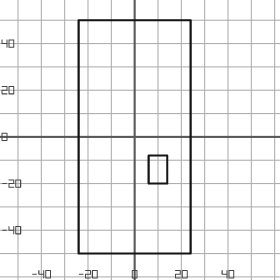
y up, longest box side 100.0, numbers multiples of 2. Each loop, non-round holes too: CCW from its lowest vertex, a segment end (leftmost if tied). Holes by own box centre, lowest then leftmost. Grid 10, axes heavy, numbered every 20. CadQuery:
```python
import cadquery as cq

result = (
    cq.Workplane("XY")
    .moveTo(-24.0, -50.0)
    .lineTo(24.0, -50.0)
    .lineTo(24.0, 50.0)
    .lineTo(-24.0, 50.0)
    .close()
    .moveTo(6.0, -20.0)
    .lineTo(14.0, -20.0)
    .lineTo(14.0, -8.0)
    .lineTo(6.0, -8.0)
    .close()
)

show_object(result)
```